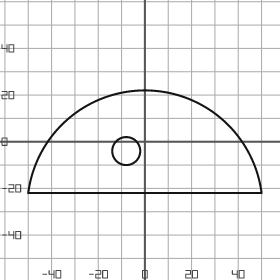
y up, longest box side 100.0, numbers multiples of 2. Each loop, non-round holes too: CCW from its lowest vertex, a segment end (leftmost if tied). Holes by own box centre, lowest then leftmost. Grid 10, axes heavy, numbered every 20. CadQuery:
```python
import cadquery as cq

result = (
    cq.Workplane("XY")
    .moveTo(-50.0, -22.0)
    .lineTo(50.0, -22.0)
    .threePointArc((0.0, 22.0), (-50.0, -22.0))
    .close()
    .moveTo(-8.0, -4.0)
    .circle(6.0)
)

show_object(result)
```